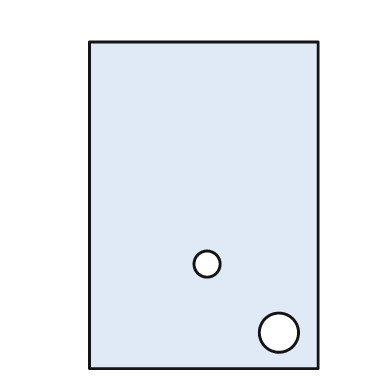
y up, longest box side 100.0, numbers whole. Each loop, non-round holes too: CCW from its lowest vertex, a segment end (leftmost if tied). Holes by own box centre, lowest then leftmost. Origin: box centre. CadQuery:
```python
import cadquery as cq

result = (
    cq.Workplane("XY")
    .moveTo(-35.0, -50.0)
    .lineTo(35.0, -50.0)
    .lineTo(35.0, 50.0)
    .lineTo(-35.0, 50.0)
    .close()
    .moveTo(23.0, -39.0)
    .circle(6.0)
    .moveTo(1.0, -18.0)
    .circle(4.0)
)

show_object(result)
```